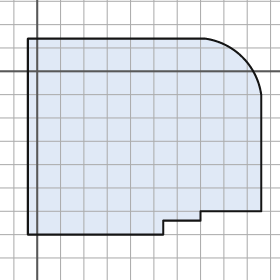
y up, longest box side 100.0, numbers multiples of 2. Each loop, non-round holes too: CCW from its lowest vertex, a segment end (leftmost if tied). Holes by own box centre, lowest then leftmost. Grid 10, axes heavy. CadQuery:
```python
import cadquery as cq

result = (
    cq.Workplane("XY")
    .moveTo(-4.0, -70.0)
    .lineTo(54.0, -70.0)
    .lineTo(54.0, -64.0)
    .lineTo(70.0, -64.0)
    .lineTo(70.0, -60.0)
    .lineTo(96.0, -60.0)
    .lineTo(96.0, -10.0)
    .threePointArc((88.0, 6.0), (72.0, 14.0))
    .lineTo(-4.0, 14.0)
    .close()
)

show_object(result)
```